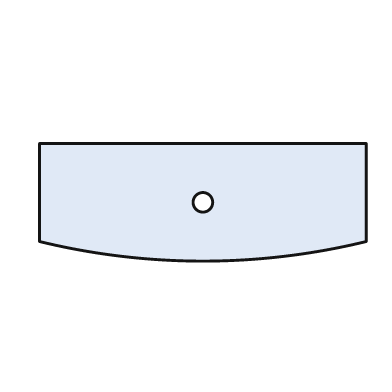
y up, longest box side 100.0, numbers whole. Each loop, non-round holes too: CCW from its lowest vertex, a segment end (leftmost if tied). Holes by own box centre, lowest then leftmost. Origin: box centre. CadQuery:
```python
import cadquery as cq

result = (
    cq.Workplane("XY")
    .moveTo(-50.0, -12.0)
    .threePointArc((0.0, -18.0), (50.0, -12.0))
    .lineTo(50.0, 18.0)
    .lineTo(-50.0, 18.0)
    .close()
    .moveTo(0.0, 0.0)
    .circle(3.0)
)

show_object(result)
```